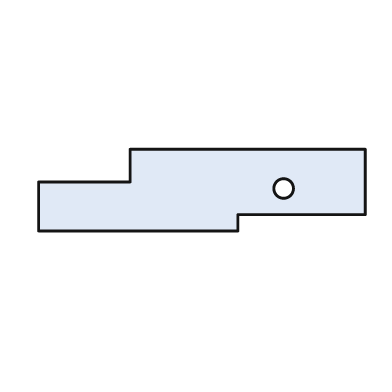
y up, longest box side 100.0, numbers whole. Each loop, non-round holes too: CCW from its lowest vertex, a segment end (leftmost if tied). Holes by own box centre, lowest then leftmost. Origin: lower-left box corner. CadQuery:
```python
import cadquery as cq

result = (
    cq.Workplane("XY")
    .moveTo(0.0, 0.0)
    .lineTo(61.0, 0.0)
    .lineTo(61.0, 5.0)
    .lineTo(100.0, 5.0)
    .lineTo(100.0, 25.0)
    .lineTo(28.0, 25.0)
    .lineTo(28.0, 15.0)
    .lineTo(0.0, 15.0)
    .close()
    .moveTo(75.0, 13.0)
    .circle(3.0)
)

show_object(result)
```